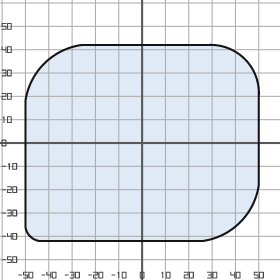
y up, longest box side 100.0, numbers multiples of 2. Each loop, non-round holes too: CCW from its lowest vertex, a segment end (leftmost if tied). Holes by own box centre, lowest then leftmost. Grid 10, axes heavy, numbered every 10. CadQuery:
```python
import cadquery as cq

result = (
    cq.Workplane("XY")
    .moveTo(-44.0, -42.0)
    .lineTo(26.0, -42.0)
    .threePointArc((42.0, -34.0), (50.0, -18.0))
    .lineTo(50.0, 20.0)
    .threePointArc((44.0, 36.0), (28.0, 42.0))
    .lineTo(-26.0, 42.0)
    .threePointArc((-42.0, 34.0), (-50.0, 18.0))
    .lineTo(-50.0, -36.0)
    .threePointArc((-48.0, -40.0), (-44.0, -42.0))
    .close()
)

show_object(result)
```